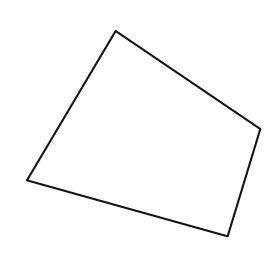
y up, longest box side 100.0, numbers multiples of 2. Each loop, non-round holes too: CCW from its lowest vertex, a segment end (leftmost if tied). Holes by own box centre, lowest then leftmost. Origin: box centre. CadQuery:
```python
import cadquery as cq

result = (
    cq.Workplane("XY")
    .moveTo(36.0, -44.0)
    .lineTo(50.0, 2.0)
    .lineTo(-12.0, 44.0)
    .lineTo(-50.0, -20.0)
    .close()
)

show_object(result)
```